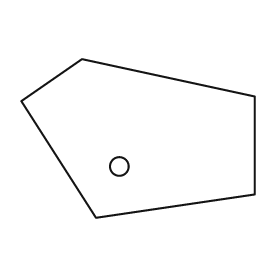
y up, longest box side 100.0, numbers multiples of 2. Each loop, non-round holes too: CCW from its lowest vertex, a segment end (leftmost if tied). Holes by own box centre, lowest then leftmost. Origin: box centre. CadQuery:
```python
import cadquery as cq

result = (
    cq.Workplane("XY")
    .moveTo(-18.0, -34.0)
    .lineTo(50.0, -24.0)
    .lineTo(50.0, 18.0)
    .lineTo(-24.0, 34.0)
    .lineTo(-50.0, 16.0)
    .close()
    .moveTo(-8.0, -12.0)
    .circle(4.0)
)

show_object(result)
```